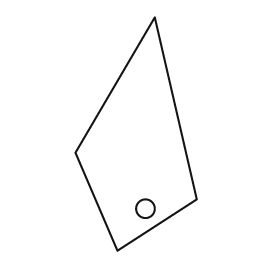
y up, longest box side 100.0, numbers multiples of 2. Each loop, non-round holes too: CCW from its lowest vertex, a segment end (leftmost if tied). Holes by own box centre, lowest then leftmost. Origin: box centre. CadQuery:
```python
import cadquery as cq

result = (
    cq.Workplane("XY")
    .moveTo(-8.0, -50.0)
    .lineTo(26.0, -28.0)
    .lineTo(8.0, 50.0)
    .lineTo(-26.0, -8.0)
    .close()
    .moveTo(4.0, -32.0)
    .circle(4.0)
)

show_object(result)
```